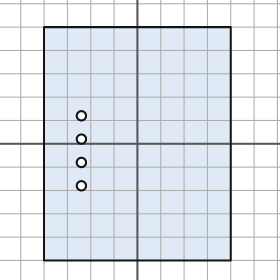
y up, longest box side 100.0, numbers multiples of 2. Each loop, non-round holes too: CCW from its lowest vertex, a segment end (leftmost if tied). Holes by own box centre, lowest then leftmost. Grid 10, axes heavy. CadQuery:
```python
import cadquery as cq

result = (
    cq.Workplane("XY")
    .moveTo(-40.0, -50.0)
    .lineTo(40.0, -50.0)
    .lineTo(40.0, 50.0)
    .lineTo(-40.0, 50.0)
    .close()
    .moveTo(-24.0, -18.0)
    .circle(2.0)
    .moveTo(-24.0, -8.0)
    .circle(2.0)
    .moveTo(-24.0, 2.0)
    .circle(2.0)
    .moveTo(-24.0, 12.0)
    .circle(2.0)
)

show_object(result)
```